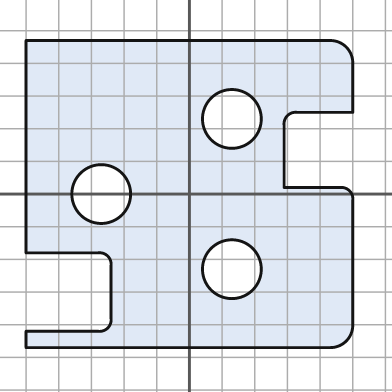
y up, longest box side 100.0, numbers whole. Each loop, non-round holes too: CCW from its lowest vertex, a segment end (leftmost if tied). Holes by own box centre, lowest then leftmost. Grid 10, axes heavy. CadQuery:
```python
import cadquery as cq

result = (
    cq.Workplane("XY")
    .moveTo(-50.0, -47.0)
    .lineTo(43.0, -47.0)
    .threePointArc((48.0, -45.0), (50.0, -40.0))
    .lineTo(50.0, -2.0)
    .threePointArc((49.0, 1.0), (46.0, 2.0))
    .lineTo(29.0, 2.0)
    .lineTo(29.0, 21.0)
    .threePointArc((30.0, 24.0), (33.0, 25.0))
    .lineTo(50.0, 25.0)
    .lineTo(50.0, 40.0)
    .threePointArc((48.0, 45.0), (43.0, 47.0))
    .lineTo(-50.0, 47.0)
    .lineTo(-50.0, -18.0)
    .lineTo(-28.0, -18.0)
    .threePointArc((-25.0, -19.0), (-24.0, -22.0))
    .lineTo(-24.0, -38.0)
    .threePointArc((-25.0, -41.0), (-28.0, -42.0))
    .lineTo(-50.0, -42.0)
    .close()
    .moveTo(13.0, -23.0)
    .circle(9.0)
    .moveTo(-27.0, 0.0)
    .circle(9.0)
    .moveTo(13.0, 23.0)
    .circle(9.0)
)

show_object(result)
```